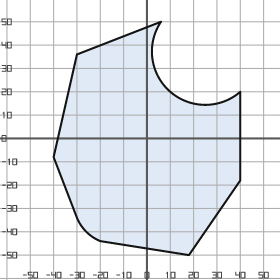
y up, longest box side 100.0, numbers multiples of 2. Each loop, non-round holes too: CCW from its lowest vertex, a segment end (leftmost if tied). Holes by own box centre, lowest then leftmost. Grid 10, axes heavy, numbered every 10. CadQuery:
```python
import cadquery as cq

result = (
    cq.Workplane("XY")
    .moveTo(18.0, -50.0)
    .lineTo(40.0, -18.0)
    .lineTo(40.0, 20.0)
    .threePointArc((10.0, 20.0), (6.0, 50.0))
    .lineTo(-30.0, 36.0)
    .lineTo(-40.0, -8.0)
    .lineTo(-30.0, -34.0)
    .threePointArc((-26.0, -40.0), (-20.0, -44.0))
    .close()
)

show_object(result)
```